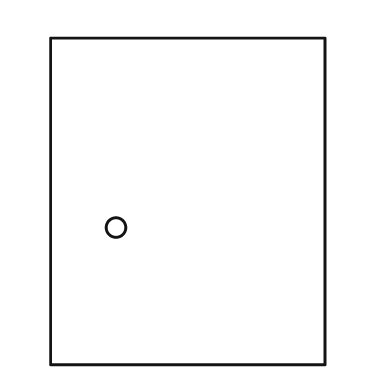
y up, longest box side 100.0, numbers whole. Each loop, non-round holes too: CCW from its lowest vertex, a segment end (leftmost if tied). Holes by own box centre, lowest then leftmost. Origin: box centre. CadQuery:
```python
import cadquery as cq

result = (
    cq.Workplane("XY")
    .moveTo(-42.0, -50.0)
    .lineTo(42.0, -50.0)
    .lineTo(42.0, 50.0)
    .lineTo(-42.0, 50.0)
    .close()
    .moveTo(-22.0, -8.0)
    .circle(3.0)
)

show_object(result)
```